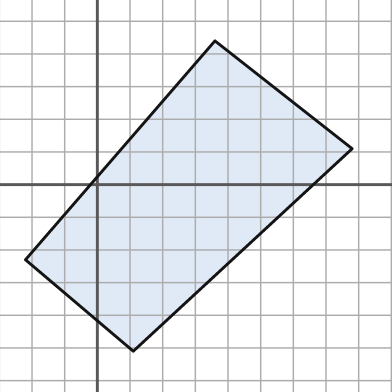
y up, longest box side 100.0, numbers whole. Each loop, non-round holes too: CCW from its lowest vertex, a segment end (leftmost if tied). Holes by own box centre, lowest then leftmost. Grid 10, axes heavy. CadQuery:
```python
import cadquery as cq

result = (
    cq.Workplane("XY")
    .moveTo(11.0, -51.0)
    .lineTo(78.0, 11.0)
    .lineTo(36.0, 44.0)
    .lineTo(-22.0, -23.0)
    .close()
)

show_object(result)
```